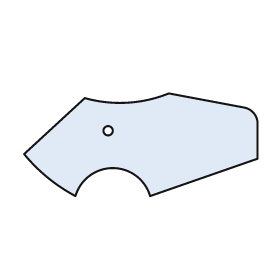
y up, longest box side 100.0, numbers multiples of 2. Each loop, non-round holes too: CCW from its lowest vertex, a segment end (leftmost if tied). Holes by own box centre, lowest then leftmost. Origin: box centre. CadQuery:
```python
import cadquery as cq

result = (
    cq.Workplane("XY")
    .moveTo(-28.0, -22.0)
    .threePointArc((-12.0, -10.0), (4.0, -22.0))
    .lineTo(50.0, -6.0)
    .lineTo(50.0, 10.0)
    .threePointArc((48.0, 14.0), (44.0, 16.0))
    .lineTo(12.0, 22.0)
    .threePointArc((-6.0, 18.0), (-24.0, 20.0))
    .lineTo(-50.0, -4.0)
    .threePointArc((-40.0, -14.0), (-28.0, -22.0))
    .close()
    .moveTo(-14.0, 6.0)
    .circle(2.0)
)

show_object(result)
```